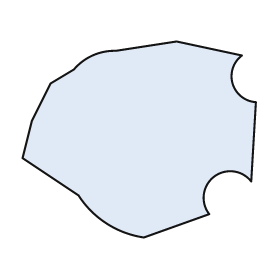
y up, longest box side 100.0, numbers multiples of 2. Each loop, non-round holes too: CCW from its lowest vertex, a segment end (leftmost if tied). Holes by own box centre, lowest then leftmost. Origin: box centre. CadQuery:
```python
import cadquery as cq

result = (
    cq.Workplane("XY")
    .moveTo(2.0, -42.0)
    .lineTo(30.0, -32.0)
    .threePointArc((32.0, -16.0), (48.0, -18.0))
    .lineTo(50.0, 16.0)
    .threePointArc((40.0, 24.0), (44.0, 36.0))
    .lineTo(16.0, 42.0)
    .lineTo(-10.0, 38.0)
    .threePointArc((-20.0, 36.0), (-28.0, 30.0))
    .lineTo(-38.0, 24.0)
    .lineTo(-46.0, 8.0)
    .lineTo(-50.0, -8.0)
    .lineTo(-26.0, -24.0)
    .threePointArc((-14.0, -36.0), (2.0, -42.0))
    .close()
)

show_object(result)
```